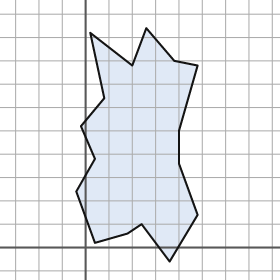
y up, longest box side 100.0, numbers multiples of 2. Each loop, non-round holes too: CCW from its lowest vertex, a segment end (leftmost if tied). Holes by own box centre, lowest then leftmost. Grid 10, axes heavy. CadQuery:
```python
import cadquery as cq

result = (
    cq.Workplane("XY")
    .moveTo(36.0, -6.0)
    .lineTo(48.0, 14.0)
    .lineTo(40.0, 36.0)
    .lineTo(40.0, 50.0)
    .lineTo(48.0, 78.0)
    .lineTo(38.0, 80.0)
    .lineTo(26.0, 94.0)
    .lineTo(20.0, 78.0)
    .lineTo(2.0, 92.0)
    .lineTo(8.0, 64.0)
    .lineTo(-2.0, 52.0)
    .lineTo(4.0, 38.0)
    .lineTo(-4.0, 24.0)
    .lineTo(4.0, 2.0)
    .lineTo(18.0, 6.0)
    .lineTo(24.0, 10.0)
    .close()
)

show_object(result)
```